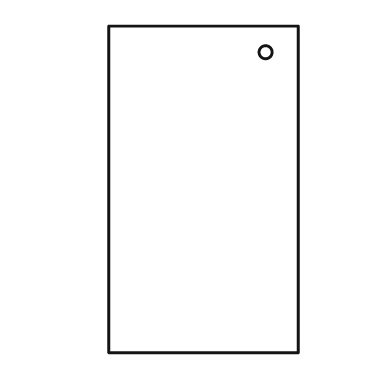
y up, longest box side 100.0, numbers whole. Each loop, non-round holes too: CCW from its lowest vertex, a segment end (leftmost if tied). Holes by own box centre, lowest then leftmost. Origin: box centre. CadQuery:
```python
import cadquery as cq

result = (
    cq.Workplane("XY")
    .moveTo(-29.0, -50.0)
    .lineTo(29.0, -50.0)
    .lineTo(29.0, 50.0)
    .lineTo(-29.0, 50.0)
    .close()
    .moveTo(19.0, 42.0)
    .circle(2.0)
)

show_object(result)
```